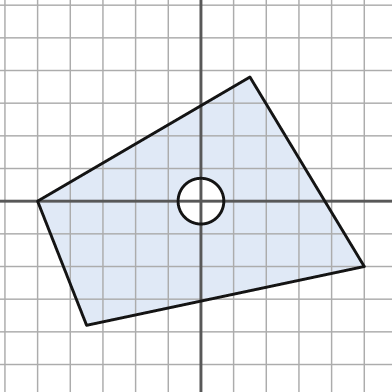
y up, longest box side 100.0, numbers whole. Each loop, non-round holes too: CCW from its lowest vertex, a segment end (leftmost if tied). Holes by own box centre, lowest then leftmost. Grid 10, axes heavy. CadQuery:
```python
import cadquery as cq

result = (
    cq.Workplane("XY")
    .moveTo(-35.0, -38.0)
    .lineTo(50.0, -20.0)
    .lineTo(15.0, 38.0)
    .lineTo(-50.0, 0.0)
    .close()
    .moveTo(0.0, 0.0)
    .circle(7.0)
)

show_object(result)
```